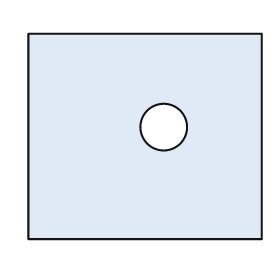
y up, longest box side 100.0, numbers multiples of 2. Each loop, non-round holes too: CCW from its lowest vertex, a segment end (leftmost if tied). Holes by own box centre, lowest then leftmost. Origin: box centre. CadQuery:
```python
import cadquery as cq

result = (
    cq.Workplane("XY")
    .moveTo(-50.0, -44.0)
    .lineTo(50.0, -44.0)
    .lineTo(50.0, 44.0)
    .lineTo(-50.0, 44.0)
    .close()
    .moveTo(8.0, 4.0)
    .circle(10.0)
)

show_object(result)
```